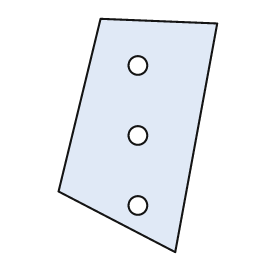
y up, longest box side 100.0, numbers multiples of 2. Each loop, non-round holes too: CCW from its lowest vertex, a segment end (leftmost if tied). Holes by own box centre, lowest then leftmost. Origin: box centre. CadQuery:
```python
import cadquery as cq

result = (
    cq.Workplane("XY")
    .moveTo(16.0, -50.0)
    .lineTo(34.0, 48.0)
    .lineTo(-16.0, 50.0)
    .lineTo(-34.0, -24.0)
    .close()
    .moveTo(0.0, -30.0)
    .circle(4.0)
    .moveTo(0.0, 0.0)
    .circle(4.0)
    .moveTo(0.0, 30.0)
    .circle(4.0)
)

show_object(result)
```